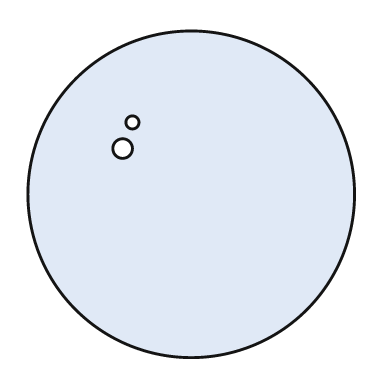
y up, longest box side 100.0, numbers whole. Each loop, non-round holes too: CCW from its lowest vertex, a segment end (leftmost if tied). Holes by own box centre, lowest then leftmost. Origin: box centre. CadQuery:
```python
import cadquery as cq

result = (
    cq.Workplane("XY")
    .moveTo(0.0, 0.0)
    .circle(50.0)
    .moveTo(-21.0, 14.0)
    .circle(3.0)
    .moveTo(-18.0, 22.0)
    .circle(2.0)
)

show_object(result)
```